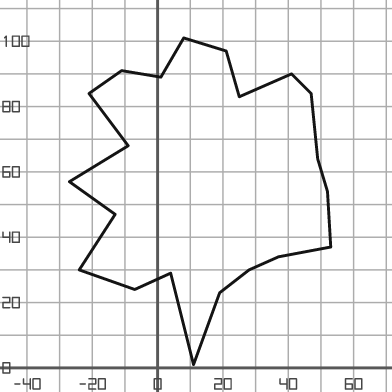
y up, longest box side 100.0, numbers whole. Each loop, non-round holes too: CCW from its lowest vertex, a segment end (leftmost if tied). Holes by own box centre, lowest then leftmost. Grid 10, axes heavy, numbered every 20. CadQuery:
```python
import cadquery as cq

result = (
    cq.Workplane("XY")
    .moveTo(11.0, 1.0)
    .lineTo(19.0, 23.0)
    .lineTo(28.0, 30.0)
    .lineTo(37.0, 34.0)
    .lineTo(53.0, 37.0)
    .lineTo(52.0, 54.0)
    .lineTo(49.0, 64.0)
    .lineTo(47.0, 84.0)
    .lineTo(41.0, 90.0)
    .lineTo(25.0, 83.0)
    .lineTo(21.0, 97.0)
    .lineTo(8.0, 101.0)
    .lineTo(1.0, 89.0)
    .lineTo(-11.0, 91.0)
    .lineTo(-21.0, 84.0)
    .lineTo(-9.0, 68.0)
    .lineTo(-27.0, 57.0)
    .lineTo(-13.0, 47.0)
    .lineTo(-24.0, 30.0)
    .lineTo(-7.0, 24.0)
    .lineTo(4.0, 29.0)
    .close()
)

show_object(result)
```